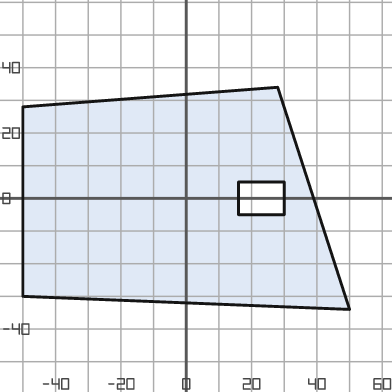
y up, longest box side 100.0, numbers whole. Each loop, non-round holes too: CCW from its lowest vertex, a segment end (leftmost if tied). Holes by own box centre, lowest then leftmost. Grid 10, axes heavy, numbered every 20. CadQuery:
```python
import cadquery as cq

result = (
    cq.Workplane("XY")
    .moveTo(50.0, -34.0)
    .lineTo(28.0, 34.0)
    .lineTo(-50.0, 28.0)
    .lineTo(-50.0, -30.0)
    .close()
    .moveTo(16.0, -5.0)
    .lineTo(30.0, -5.0)
    .lineTo(30.0, 5.0)
    .lineTo(16.0, 5.0)
    .close()
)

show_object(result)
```